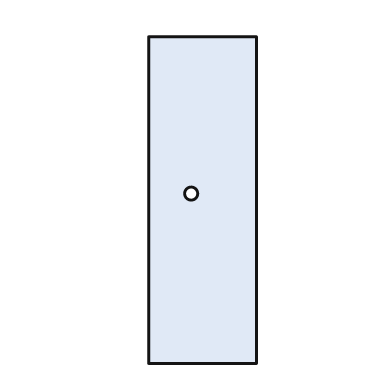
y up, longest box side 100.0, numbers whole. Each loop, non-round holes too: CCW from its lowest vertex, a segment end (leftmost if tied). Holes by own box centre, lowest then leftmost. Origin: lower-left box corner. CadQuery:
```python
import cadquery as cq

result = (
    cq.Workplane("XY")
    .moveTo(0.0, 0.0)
    .lineTo(33.0, 0.0)
    .lineTo(33.0, 100.0)
    .lineTo(0.0, 100.0)
    .close()
    .moveTo(13.0, 52.0)
    .circle(2.0)
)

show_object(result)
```